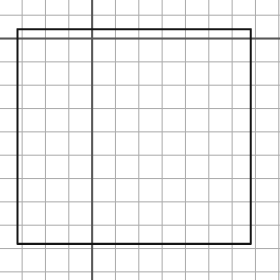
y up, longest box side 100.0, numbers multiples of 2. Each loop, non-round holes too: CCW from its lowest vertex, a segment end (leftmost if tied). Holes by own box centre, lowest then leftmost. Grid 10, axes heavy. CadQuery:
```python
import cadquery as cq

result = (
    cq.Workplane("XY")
    .moveTo(-32.0, -88.0)
    .lineTo(68.0, -88.0)
    .lineTo(68.0, 4.0)
    .lineTo(-32.0, 4.0)
    .close()
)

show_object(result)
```